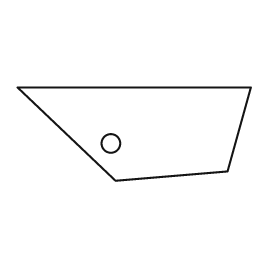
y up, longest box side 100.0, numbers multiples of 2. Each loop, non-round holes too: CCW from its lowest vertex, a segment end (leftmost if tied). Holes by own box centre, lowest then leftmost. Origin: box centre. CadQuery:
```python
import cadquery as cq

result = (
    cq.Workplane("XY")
    .moveTo(-8.0, -20.0)
    .lineTo(40.0, -16.0)
    .lineTo(50.0, 20.0)
    .lineTo(-50.0, 20.0)
    .close()
    .moveTo(-10.0, -4.0)
    .circle(4.0)
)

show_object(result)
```